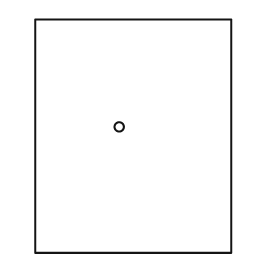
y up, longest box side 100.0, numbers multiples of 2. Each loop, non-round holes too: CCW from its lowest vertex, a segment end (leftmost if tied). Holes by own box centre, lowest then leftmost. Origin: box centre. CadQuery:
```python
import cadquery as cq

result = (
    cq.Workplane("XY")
    .moveTo(-42.0, -50.0)
    .lineTo(42.0, -50.0)
    .lineTo(42.0, 50.0)
    .lineTo(-42.0, 50.0)
    .close()
    .moveTo(-6.0, 4.0)
    .circle(2.0)
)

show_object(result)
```